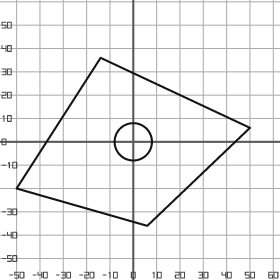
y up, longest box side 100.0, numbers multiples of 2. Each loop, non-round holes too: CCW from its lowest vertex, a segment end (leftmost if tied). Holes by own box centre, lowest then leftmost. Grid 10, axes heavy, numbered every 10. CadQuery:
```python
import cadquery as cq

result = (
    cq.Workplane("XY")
    .moveTo(6.0, -36.0)
    .lineTo(50.0, 6.0)
    .lineTo(-14.0, 36.0)
    .lineTo(-50.0, -20.0)
    .close()
    .moveTo(0.0, 0.0)
    .circle(8.0)
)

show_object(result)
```